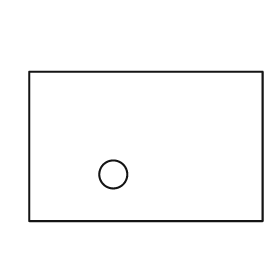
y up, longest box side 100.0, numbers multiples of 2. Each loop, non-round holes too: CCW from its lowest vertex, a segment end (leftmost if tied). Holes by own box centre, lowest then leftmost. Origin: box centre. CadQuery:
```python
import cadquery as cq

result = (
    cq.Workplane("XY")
    .moveTo(-50.0, -32.0)
    .lineTo(50.0, -32.0)
    .lineTo(50.0, 32.0)
    .lineTo(-50.0, 32.0)
    .close()
    .moveTo(-14.0, -12.0)
    .circle(6.0)
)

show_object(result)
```